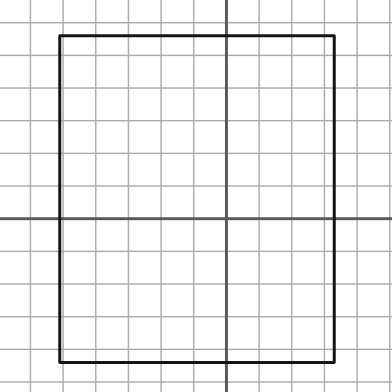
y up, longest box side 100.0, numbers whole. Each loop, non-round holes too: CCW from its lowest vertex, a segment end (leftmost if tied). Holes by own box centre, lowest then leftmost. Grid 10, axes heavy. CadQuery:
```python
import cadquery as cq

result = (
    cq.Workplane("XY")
    .moveTo(-51.0, -44.0)
    .lineTo(33.0, -44.0)
    .lineTo(33.0, 56.0)
    .lineTo(-51.0, 56.0)
    .close()
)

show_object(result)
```